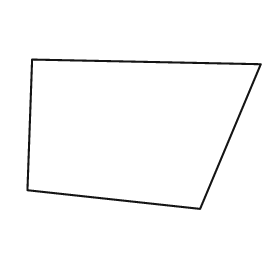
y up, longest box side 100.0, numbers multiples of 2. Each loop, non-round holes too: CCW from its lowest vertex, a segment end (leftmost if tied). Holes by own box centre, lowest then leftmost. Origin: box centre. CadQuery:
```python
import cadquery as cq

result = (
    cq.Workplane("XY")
    .moveTo(24.0, -32.0)
    .lineTo(50.0, 30.0)
    .lineTo(-48.0, 32.0)
    .lineTo(-50.0, -24.0)
    .close()
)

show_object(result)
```